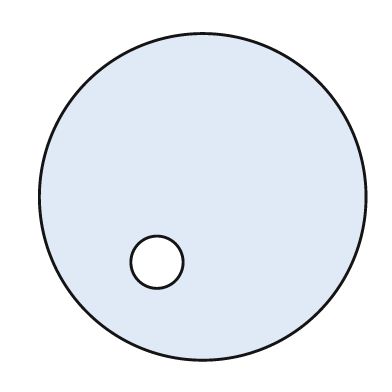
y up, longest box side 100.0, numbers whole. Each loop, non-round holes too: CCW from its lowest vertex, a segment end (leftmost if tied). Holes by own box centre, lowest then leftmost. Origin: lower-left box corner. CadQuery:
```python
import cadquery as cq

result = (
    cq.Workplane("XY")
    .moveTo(50.0, 50.0)
    .circle(50.0)
    .moveTo(36.0, 30.0)
    .circle(8.0)
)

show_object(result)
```